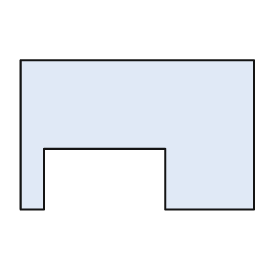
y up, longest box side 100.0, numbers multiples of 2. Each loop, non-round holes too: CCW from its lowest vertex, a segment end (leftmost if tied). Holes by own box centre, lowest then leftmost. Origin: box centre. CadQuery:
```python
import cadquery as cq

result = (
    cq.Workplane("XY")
    .moveTo(-50.0, -32.0)
    .lineTo(-40.0, -32.0)
    .lineTo(-40.0, -6.0)
    .lineTo(12.0, -6.0)
    .lineTo(12.0, -32.0)
    .lineTo(50.0, -32.0)
    .lineTo(50.0, 32.0)
    .lineTo(-50.0, 32.0)
    .close()
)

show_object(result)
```